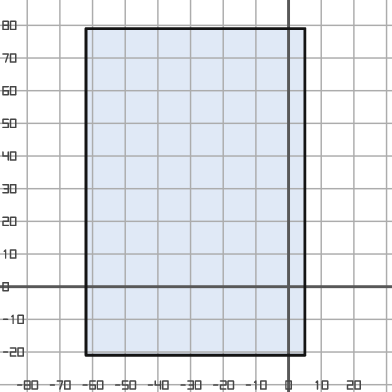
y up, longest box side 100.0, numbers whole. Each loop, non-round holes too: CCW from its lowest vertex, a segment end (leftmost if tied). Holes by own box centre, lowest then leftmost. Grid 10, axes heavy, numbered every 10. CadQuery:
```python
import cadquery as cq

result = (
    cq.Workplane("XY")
    .moveTo(-62.0, -21.0)
    .lineTo(5.0, -21.0)
    .lineTo(5.0, 79.0)
    .lineTo(-62.0, 79.0)
    .close()
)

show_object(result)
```